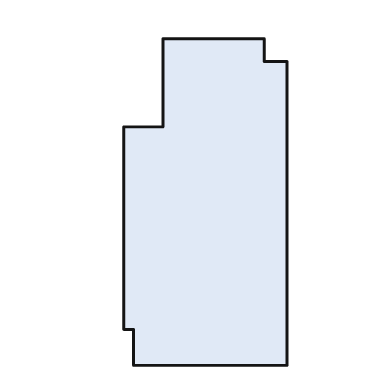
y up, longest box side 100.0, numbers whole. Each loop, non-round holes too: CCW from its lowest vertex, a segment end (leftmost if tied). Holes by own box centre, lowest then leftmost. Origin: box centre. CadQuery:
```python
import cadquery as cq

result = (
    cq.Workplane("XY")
    .moveTo(-22.0, -50.0)
    .lineTo(25.0, -50.0)
    .lineTo(25.0, 43.0)
    .lineTo(18.0, 43.0)
    .lineTo(18.0, 50.0)
    .lineTo(-13.0, 50.0)
    .lineTo(-13.0, 23.0)
    .lineTo(-25.0, 23.0)
    .lineTo(-25.0, -39.0)
    .lineTo(-22.0, -39.0)
    .close()
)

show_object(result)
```